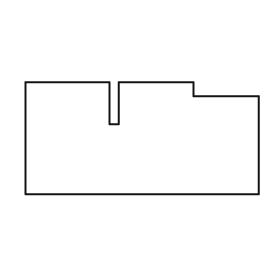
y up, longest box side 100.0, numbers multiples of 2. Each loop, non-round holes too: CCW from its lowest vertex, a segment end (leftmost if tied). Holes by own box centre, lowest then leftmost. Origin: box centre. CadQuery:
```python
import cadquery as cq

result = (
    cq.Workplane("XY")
    .moveTo(-50.0, -24.0)
    .lineTo(50.0, -24.0)
    .lineTo(50.0, 18.0)
    .lineTo(22.0, 18.0)
    .lineTo(22.0, 24.0)
    .lineTo(-10.0, 24.0)
    .lineTo(-10.0, 6.0)
    .lineTo(-14.0, 6.0)
    .lineTo(-14.0, 24.0)
    .lineTo(-50.0, 24.0)
    .close()
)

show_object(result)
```